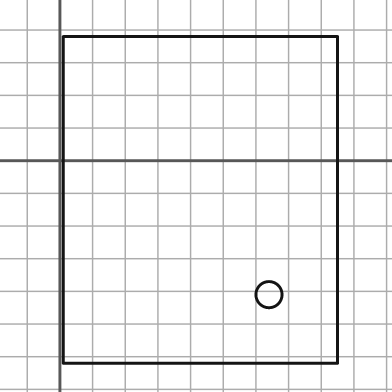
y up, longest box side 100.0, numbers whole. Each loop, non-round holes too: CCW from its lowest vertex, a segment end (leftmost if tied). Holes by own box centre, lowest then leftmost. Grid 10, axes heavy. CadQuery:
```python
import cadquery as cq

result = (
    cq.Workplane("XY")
    .moveTo(1.0, -62.0)
    .lineTo(85.0, -62.0)
    .lineTo(85.0, 38.0)
    .lineTo(1.0, 38.0)
    .close()
    .moveTo(64.0, -41.0)
    .circle(4.0)
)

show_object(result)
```